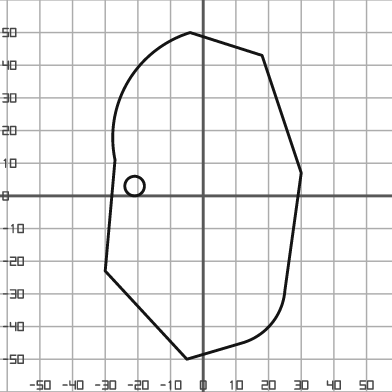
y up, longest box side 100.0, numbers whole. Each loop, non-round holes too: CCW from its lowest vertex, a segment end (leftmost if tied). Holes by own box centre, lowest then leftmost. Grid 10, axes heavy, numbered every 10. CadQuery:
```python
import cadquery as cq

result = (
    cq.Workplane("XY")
    .moveTo(-5.0, -50.0)
    .lineTo(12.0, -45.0)
    .threePointArc((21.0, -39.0), (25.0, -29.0))
    .lineTo(30.0, 7.0)
    .lineTo(18.0, 43.0)
    .lineTo(-4.0, 50.0)
    .threePointArc((-23.0, 35.0), (-27.0, 11.0))
    .lineTo(-30.0, -23.0)
    .close()
    .moveTo(-21.0, 3.0)
    .circle(3.0)
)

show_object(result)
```